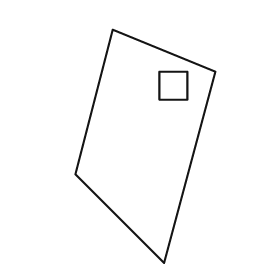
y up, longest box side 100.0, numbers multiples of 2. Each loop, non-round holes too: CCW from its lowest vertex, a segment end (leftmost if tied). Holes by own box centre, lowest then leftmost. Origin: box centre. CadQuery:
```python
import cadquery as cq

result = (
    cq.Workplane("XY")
    .moveTo(8.0, -50.0)
    .lineTo(30.0, 32.0)
    .lineTo(-14.0, 50.0)
    .lineTo(-30.0, -12.0)
    .close()
    .moveTo(6.0, 20.0)
    .lineTo(18.0, 20.0)
    .lineTo(18.0, 32.0)
    .lineTo(6.0, 32.0)
    .close()
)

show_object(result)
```